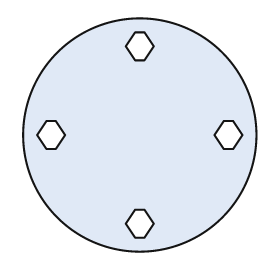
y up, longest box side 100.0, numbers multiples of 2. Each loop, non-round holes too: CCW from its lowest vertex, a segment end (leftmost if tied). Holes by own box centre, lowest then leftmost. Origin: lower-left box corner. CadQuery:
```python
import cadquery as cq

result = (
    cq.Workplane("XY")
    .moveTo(50.0, 50.0)
    .circle(50.0)
    .moveTo(48.0, 6.0)
    .lineTo(52.0, 6.0)
    .lineTo(56.0, 12.0)
    .lineTo(52.0, 18.0)
    .lineTo(48.0, 18.0)
    .lineTo(44.0, 12.0)
    .close()
    .moveTo(10.0, 44.0)
    .lineTo(14.0, 44.0)
    .lineTo(18.0, 50.0)
    .lineTo(14.0, 56.0)
    .lineTo(10.0, 56.0)
    .lineTo(6.0, 50.0)
    .close()
    .moveTo(86.0, 44.0)
    .lineTo(90.0, 44.0)
    .lineTo(94.0, 50.0)
    .lineTo(90.0, 56.0)
    .lineTo(86.0, 56.0)
    .lineTo(82.0, 50.0)
    .close()
    .moveTo(48.0, 82.0)
    .lineTo(52.0, 82.0)
    .lineTo(56.0, 88.0)
    .lineTo(52.0, 94.0)
    .lineTo(48.0, 94.0)
    .lineTo(44.0, 88.0)
    .close()
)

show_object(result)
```